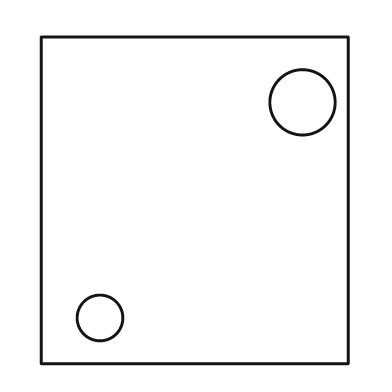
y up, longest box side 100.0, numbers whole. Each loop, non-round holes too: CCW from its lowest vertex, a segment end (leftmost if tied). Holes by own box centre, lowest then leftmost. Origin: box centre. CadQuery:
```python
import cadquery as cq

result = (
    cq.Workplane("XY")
    .moveTo(-47.0, -50.0)
    .lineTo(47.0, -50.0)
    .lineTo(47.0, 50.0)
    .lineTo(-47.0, 50.0)
    .close()
    .moveTo(-29.0, -36.0)
    .circle(7.0)
    .moveTo(33.0, 30.0)
    .circle(10.0)
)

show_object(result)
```